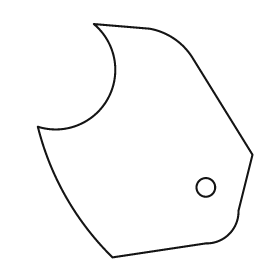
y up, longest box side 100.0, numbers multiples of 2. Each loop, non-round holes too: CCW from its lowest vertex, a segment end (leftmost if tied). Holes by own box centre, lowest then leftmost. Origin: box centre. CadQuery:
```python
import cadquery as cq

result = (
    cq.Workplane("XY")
    .moveTo(-14.0, -50.0)
    .lineTo(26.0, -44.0)
    .threePointArc((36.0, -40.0), (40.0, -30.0))
    .lineTo(46.0, -6.0)
    .lineTo(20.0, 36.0)
    .threePointArc((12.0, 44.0), (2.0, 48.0))
    .lineTo(-22.0, 50.0)
    .threePointArc((-16.0, 18.0), (-46.0, 6.0))
    .threePointArc((-34.0, -24.0), (-14.0, -50.0))
    .close()
    .moveTo(26.0, -20.0)
    .circle(4.0)
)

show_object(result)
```